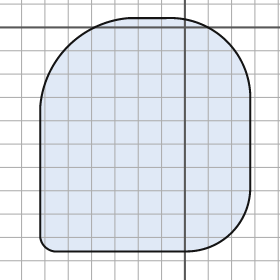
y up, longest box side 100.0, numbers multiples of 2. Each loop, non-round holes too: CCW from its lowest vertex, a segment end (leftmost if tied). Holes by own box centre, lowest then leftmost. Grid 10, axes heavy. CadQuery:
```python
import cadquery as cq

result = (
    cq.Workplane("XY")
    .moveTo(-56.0, -96.0)
    .lineTo(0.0, -96.0)
    .threePointArc((20.0, -88.0), (28.0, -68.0))
    .lineTo(28.0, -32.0)
    .threePointArc((18.0, -6.0), (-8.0, 4.0))
    .lineTo(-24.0, 4.0)
    .threePointArc((-50.0, -8.0), (-62.0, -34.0))
    .lineTo(-62.0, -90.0)
    .threePointArc((-60.0, -94.0), (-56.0, -96.0))
    .close()
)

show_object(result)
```